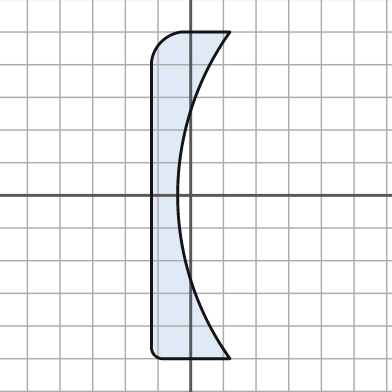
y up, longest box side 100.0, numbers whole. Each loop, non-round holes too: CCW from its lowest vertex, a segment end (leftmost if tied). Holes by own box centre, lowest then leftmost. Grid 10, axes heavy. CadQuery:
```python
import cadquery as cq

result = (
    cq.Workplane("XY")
    .moveTo(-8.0, -50.0)
    .lineTo(12.0, -50.0)
    .threePointArc((-4.0, 0.0), (12.0, 50.0))
    .lineTo(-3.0, 50.0)
    .threePointArc((-9.0, 47.0), (-12.0, 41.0))
    .lineTo(-12.0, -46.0)
    .threePointArc((-11.0, -49.0), (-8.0, -50.0))
    .close()
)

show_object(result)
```